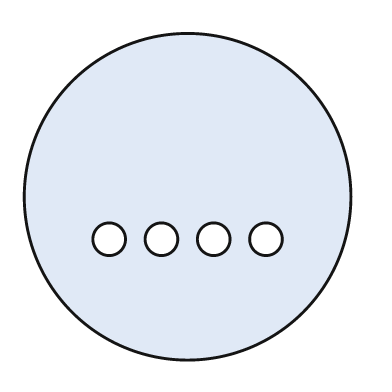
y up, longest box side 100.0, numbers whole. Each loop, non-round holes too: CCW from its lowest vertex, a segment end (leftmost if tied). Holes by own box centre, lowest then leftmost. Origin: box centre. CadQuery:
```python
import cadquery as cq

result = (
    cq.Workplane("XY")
    .moveTo(0.0, 0.0)
    .circle(50.0)
    .moveTo(-24.0, -13.0)
    .circle(5.0)
    .moveTo(-8.0, -13.0)
    .circle(5.0)
    .moveTo(8.0, -13.0)
    .circle(5.0)
    .moveTo(24.0, -13.0)
    .circle(5.0)
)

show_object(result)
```